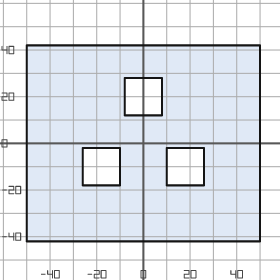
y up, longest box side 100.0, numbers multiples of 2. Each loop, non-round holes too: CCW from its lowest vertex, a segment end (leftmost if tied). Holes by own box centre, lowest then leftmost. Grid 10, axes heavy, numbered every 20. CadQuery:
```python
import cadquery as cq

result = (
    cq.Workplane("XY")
    .moveTo(-50.0, -42.0)
    .lineTo(50.0, -42.0)
    .lineTo(50.0, 42.0)
    .lineTo(-50.0, 42.0)
    .close()
    .moveTo(-26.0, -18.0)
    .lineTo(-10.0, -18.0)
    .lineTo(-10.0, -2.0)
    .lineTo(-26.0, -2.0)
    .close()
    .moveTo(10.0, -18.0)
    .lineTo(26.0, -18.0)
    .lineTo(26.0, -2.0)
    .lineTo(10.0, -2.0)
    .close()
    .moveTo(-8.0, 12.0)
    .lineTo(8.0, 12.0)
    .lineTo(8.0, 28.0)
    .lineTo(-8.0, 28.0)
    .close()
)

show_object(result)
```